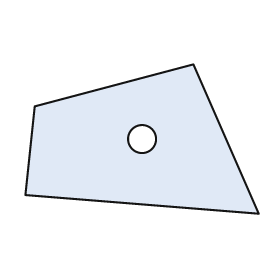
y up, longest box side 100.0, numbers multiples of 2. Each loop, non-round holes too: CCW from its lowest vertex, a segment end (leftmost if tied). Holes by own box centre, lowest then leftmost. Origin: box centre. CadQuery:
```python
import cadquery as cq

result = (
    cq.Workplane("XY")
    .moveTo(50.0, -32.0)
    .lineTo(22.0, 32.0)
    .lineTo(-46.0, 14.0)
    .lineTo(-50.0, -24.0)
    .close()
    .moveTo(0.0, 0.0)
    .circle(6.0)
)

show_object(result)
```